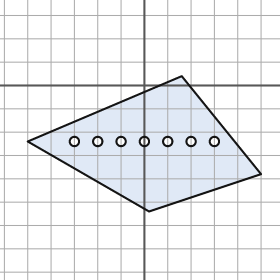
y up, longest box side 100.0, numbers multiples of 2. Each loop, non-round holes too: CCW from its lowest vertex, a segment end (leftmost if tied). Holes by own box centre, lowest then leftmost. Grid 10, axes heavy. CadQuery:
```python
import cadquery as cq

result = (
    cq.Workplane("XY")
    .moveTo(2.0, -54.0)
    .lineTo(50.0, -38.0)
    .lineTo(16.0, 4.0)
    .lineTo(-50.0, -24.0)
    .close()
    .moveTo(-30.0, -24.0)
    .circle(2.0)
    .moveTo(-20.0, -24.0)
    .circle(2.0)
    .moveTo(-10.0, -24.0)
    .circle(2.0)
    .moveTo(0.0, -24.0)
    .circle(2.0)
    .moveTo(10.0, -24.0)
    .circle(2.0)
    .moveTo(20.0, -24.0)
    .circle(2.0)
    .moveTo(30.0, -24.0)
    .circle(2.0)
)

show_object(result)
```